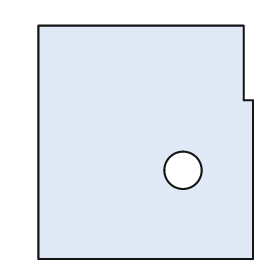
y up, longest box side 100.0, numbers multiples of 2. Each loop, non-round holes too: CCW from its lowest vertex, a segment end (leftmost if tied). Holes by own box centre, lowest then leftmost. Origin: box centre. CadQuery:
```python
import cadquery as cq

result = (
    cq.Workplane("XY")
    .moveTo(-46.0, -50.0)
    .lineTo(46.0, -50.0)
    .lineTo(46.0, 18.0)
    .lineTo(42.0, 18.0)
    .lineTo(42.0, 50.0)
    .lineTo(-46.0, 50.0)
    .close()
    .moveTo(16.0, -12.0)
    .circle(8.0)
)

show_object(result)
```